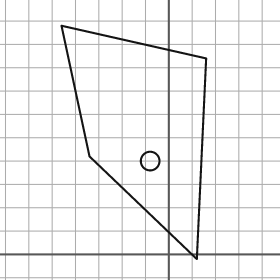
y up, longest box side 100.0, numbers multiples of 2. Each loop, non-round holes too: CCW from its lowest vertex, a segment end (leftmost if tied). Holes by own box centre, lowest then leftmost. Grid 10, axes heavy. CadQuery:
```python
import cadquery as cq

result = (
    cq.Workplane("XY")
    .moveTo(12.0, -2.0)
    .lineTo(16.0, 84.0)
    .lineTo(-46.0, 98.0)
    .lineTo(-34.0, 42.0)
    .close()
    .moveTo(-8.0, 40.0)
    .circle(4.0)
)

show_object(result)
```